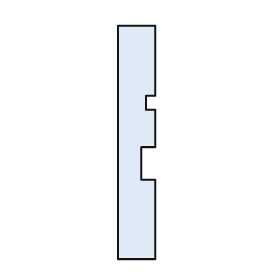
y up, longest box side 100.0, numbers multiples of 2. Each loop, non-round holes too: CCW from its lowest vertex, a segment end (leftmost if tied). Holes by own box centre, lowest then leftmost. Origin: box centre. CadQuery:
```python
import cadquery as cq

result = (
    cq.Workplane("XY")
    .moveTo(-8.0, -50.0)
    .lineTo(8.0, -50.0)
    .lineTo(8.0, -16.0)
    .lineTo(2.0, -16.0)
    .lineTo(2.0, -2.0)
    .lineTo(8.0, -2.0)
    .lineTo(8.0, 14.0)
    .lineTo(4.0, 14.0)
    .lineTo(4.0, 20.0)
    .lineTo(8.0, 20.0)
    .lineTo(8.0, 50.0)
    .lineTo(-8.0, 50.0)
    .close()
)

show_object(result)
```